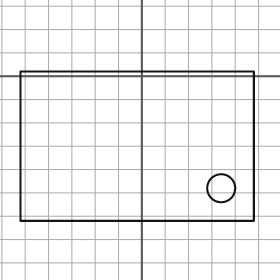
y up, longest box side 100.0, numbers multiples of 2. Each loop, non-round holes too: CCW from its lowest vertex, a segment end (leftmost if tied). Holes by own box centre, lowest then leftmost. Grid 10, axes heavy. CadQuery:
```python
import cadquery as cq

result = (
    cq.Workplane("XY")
    .moveTo(-52.0, -62.0)
    .lineTo(48.0, -62.0)
    .lineTo(48.0, 2.0)
    .lineTo(-52.0, 2.0)
    .close()
    .moveTo(34.0, -48.0)
    .circle(6.0)
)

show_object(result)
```